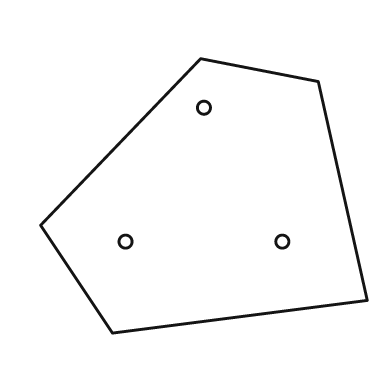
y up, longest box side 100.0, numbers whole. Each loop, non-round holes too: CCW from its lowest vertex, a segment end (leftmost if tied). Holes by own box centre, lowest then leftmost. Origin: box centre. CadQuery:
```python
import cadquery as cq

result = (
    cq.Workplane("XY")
    .moveTo(-28.0, -42.0)
    .lineTo(50.0, -32.0)
    .lineTo(35.0, 35.0)
    .lineTo(-1.0, 42.0)
    .lineTo(-50.0, -9.0)
    .close()
    .moveTo(-24.0, -14.0)
    .circle(2.0)
    .moveTo(24.0, -14.0)
    .circle(2.0)
    .moveTo(0.0, 27.0)
    .circle(2.0)
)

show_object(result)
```